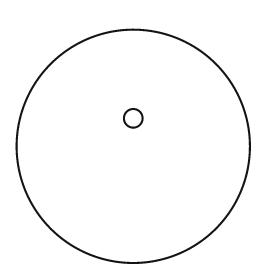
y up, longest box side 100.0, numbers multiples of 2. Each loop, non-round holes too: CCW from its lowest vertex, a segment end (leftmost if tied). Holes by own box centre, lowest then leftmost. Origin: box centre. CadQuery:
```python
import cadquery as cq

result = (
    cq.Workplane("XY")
    .moveTo(0.0, 0.0)
    .circle(50.0)
    .moveTo(0.0, 12.0)
    .circle(4.0)
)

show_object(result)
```